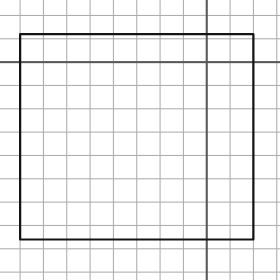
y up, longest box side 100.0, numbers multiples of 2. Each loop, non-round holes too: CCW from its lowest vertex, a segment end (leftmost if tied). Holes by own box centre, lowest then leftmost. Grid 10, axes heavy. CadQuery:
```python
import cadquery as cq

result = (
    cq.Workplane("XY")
    .moveTo(-80.0, -76.0)
    .lineTo(20.0, -76.0)
    .lineTo(20.0, 12.0)
    .lineTo(-80.0, 12.0)
    .close()
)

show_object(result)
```